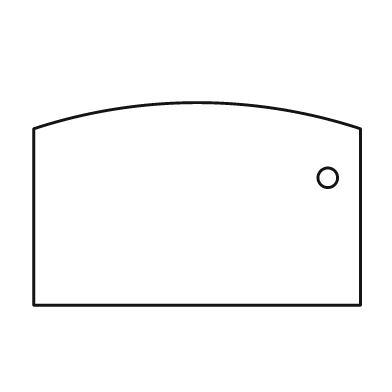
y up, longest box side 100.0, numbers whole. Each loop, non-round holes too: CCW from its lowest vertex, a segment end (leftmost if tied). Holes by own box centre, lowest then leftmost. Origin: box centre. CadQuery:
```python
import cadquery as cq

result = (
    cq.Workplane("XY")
    .moveTo(-50.0, -31.0)
    .lineTo(50.0, -31.0)
    .lineTo(50.0, 23.0)
    .threePointArc((0.0, 31.0), (-50.0, 23.0))
    .close()
    .moveTo(40.0, 8.0)
    .circle(3.0)
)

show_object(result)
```